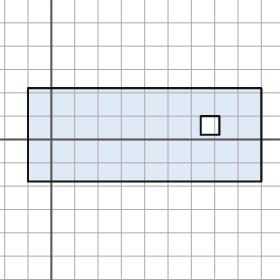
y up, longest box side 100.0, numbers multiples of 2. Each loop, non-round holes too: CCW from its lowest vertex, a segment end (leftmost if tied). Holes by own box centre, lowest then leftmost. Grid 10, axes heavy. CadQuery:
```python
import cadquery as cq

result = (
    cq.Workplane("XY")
    .moveTo(-10.0, -18.0)
    .lineTo(90.0, -18.0)
    .lineTo(90.0, 22.0)
    .lineTo(-10.0, 22.0)
    .close()
    .moveTo(64.0, 2.0)
    .lineTo(72.0, 2.0)
    .lineTo(72.0, 10.0)
    .lineTo(64.0, 10.0)
    .close()
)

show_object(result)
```